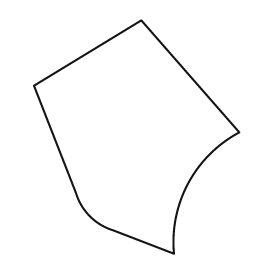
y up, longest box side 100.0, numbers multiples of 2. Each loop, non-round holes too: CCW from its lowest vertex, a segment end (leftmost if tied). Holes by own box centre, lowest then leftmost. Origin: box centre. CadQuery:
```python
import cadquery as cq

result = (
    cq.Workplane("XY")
    .moveTo(16.0, -50.0)
    .threePointArc((22.0, -20.0), (44.0, 2.0))
    .lineTo(2.0, 50.0)
    .lineTo(-44.0, 22.0)
    .lineTo(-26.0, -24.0)
    .threePointArc((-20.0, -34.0), (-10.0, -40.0))
    .close()
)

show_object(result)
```